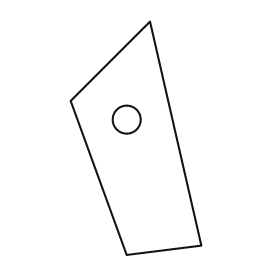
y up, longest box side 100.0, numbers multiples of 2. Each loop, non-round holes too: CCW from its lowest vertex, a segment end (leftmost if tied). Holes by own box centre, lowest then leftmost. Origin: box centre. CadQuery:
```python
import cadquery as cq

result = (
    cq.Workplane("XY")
    .moveTo(-4.0, -50.0)
    .lineTo(28.0, -46.0)
    .lineTo(6.0, 50.0)
    .lineTo(-28.0, 16.0)
    .close()
    .moveTo(-4.0, 8.0)
    .circle(6.0)
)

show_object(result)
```